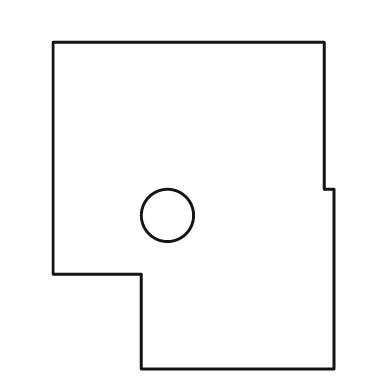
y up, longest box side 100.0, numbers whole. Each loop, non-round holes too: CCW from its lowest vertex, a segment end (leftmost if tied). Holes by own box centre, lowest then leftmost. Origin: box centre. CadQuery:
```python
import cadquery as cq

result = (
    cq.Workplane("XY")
    .moveTo(-16.0, -50.0)
    .lineTo(43.0, -50.0)
    .lineTo(43.0, 5.0)
    .lineTo(40.0, 5.0)
    .lineTo(40.0, 50.0)
    .lineTo(-43.0, 50.0)
    .lineTo(-43.0, -21.0)
    .lineTo(-16.0, -21.0)
    .close()
    .moveTo(-8.0, -3.0)
    .circle(8.0)
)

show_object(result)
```